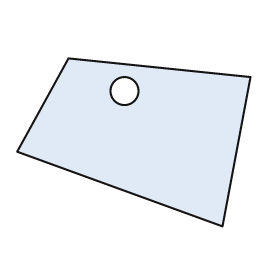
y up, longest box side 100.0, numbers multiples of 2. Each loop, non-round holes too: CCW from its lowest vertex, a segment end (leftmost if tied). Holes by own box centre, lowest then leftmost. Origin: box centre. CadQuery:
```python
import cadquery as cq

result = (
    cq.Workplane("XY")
    .moveTo(38.0, -36.0)
    .lineTo(50.0, 28.0)
    .lineTo(-28.0, 36.0)
    .lineTo(-50.0, -4.0)
    .close()
    .moveTo(-4.0, 22.0)
    .circle(6.0)
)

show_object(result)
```